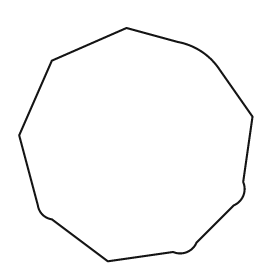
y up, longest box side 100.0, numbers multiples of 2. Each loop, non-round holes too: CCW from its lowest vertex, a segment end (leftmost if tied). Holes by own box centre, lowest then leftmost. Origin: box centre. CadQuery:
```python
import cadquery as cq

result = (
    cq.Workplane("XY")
    .moveTo(-12.0, -50.0)
    .lineTo(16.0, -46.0)
    .threePointArc((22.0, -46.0), (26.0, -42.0))
    .lineTo(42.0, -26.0)
    .threePointArc((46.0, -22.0), (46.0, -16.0))
    .lineTo(50.0, 12.0)
    .lineTo(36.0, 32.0)
    .threePointArc((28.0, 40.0), (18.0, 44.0))
    .lineTo(-4.0, 50.0)
    .lineTo(-36.0, 36.0)
    .lineTo(-50.0, 4.0)
    .lineTo(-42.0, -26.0)
    .threePointArc((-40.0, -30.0), (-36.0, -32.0))
    .close()
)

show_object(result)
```